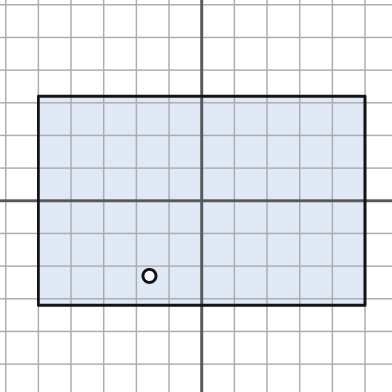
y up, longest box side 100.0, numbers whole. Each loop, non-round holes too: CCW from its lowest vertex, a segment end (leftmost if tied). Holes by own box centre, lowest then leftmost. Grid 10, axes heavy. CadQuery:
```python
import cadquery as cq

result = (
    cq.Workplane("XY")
    .moveTo(-50.0, -32.0)
    .lineTo(50.0, -32.0)
    .lineTo(50.0, 32.0)
    .lineTo(-50.0, 32.0)
    .close()
    .moveTo(-16.0, -23.0)
    .circle(2.0)
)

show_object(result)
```